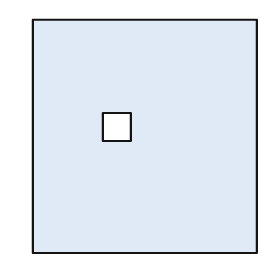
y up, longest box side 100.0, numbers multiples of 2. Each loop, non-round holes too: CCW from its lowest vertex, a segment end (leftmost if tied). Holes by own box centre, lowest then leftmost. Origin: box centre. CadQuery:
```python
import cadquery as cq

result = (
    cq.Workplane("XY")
    .moveTo(-48.0, -50.0)
    .lineTo(48.0, -50.0)
    .lineTo(48.0, 50.0)
    .lineTo(-48.0, 50.0)
    .close()
    .moveTo(-18.0, -2.0)
    .lineTo(-6.0, -2.0)
    .lineTo(-6.0, 10.0)
    .lineTo(-18.0, 10.0)
    .close()
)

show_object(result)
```